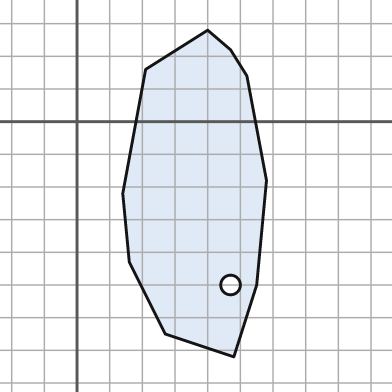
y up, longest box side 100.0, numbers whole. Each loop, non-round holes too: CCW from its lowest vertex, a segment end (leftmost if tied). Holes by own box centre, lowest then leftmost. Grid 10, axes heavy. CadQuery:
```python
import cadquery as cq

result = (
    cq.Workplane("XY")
    .moveTo(48.0, -72.0)
    .lineTo(55.0, -50.0)
    .lineTo(58.0, -18.0)
    .lineTo(52.0, 14.0)
    .lineTo(47.0, 22.0)
    .lineTo(40.0, 28.0)
    .lineTo(21.0, 16.0)
    .lineTo(14.0, -22.0)
    .lineTo(16.0, -43.0)
    .lineTo(27.0, -65.0)
    .close()
    .moveTo(47.0, -50.0)
    .circle(3.0)
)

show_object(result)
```